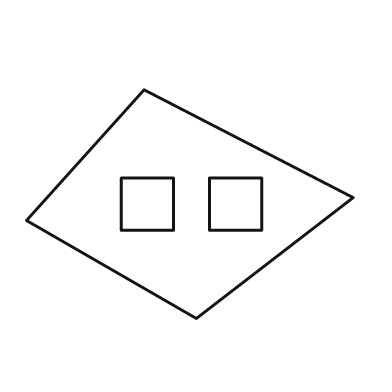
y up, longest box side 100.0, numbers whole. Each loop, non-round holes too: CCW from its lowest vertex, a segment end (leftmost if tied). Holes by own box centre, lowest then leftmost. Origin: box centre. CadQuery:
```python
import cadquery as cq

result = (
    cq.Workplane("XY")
    .moveTo(2.0, -35.0)
    .lineTo(50.0, 2.0)
    .lineTo(-14.0, 35.0)
    .lineTo(-50.0, -5.0)
    .close()
    .moveTo(-21.0, -8.0)
    .lineTo(-5.0, -8.0)
    .lineTo(-5.0, 8.0)
    .lineTo(-21.0, 8.0)
    .close()
    .moveTo(6.0, -8.0)
    .lineTo(22.0, -8.0)
    .lineTo(22.0, 8.0)
    .lineTo(6.0, 8.0)
    .close()
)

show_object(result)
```